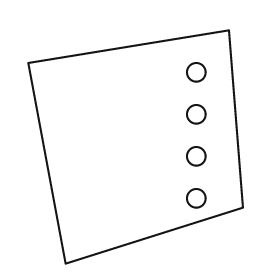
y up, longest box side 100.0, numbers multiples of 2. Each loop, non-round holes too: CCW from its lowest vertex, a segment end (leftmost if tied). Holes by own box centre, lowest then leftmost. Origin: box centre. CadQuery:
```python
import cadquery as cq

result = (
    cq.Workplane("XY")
    .moveTo(-30.0, -50.0)
    .lineTo(46.0, -26.0)
    .lineTo(40.0, 50.0)
    .lineTo(-46.0, 36.0)
    .close()
    .moveTo(26.0, -22.0)
    .circle(4.0)
    .moveTo(26.0, -4.0)
    .circle(4.0)
    .moveTo(26.0, 14.0)
    .circle(4.0)
    .moveTo(26.0, 32.0)
    .circle(4.0)
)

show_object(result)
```